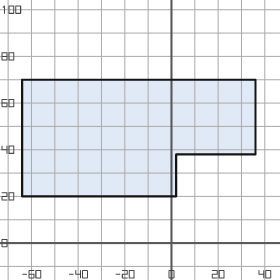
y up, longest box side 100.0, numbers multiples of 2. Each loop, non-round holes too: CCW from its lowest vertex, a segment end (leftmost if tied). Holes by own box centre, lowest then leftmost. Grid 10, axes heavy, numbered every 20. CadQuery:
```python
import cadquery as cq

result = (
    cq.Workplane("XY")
    .moveTo(-64.0, 20.0)
    .lineTo(2.0, 20.0)
    .lineTo(2.0, 38.0)
    .lineTo(36.0, 38.0)
    .lineTo(36.0, 70.0)
    .lineTo(-64.0, 70.0)
    .close()
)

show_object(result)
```